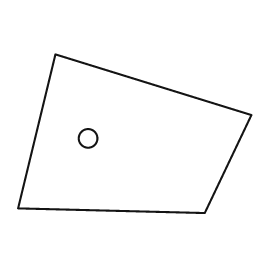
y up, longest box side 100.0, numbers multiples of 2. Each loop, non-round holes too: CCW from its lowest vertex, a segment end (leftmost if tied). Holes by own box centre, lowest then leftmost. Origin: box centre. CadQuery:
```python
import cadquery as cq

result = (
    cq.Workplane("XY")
    .moveTo(30.0, -34.0)
    .lineTo(50.0, 8.0)
    .lineTo(-34.0, 34.0)
    .lineTo(-50.0, -32.0)
    .close()
    .moveTo(-20.0, -2.0)
    .circle(4.0)
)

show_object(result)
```